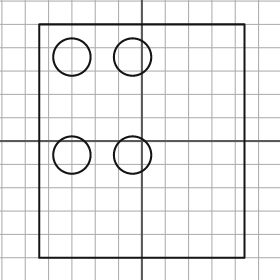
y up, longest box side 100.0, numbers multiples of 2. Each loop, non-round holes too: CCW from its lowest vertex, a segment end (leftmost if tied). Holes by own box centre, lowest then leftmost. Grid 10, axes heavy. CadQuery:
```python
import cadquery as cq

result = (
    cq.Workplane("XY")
    .moveTo(-44.0, -50.0)
    .lineTo(44.0, -50.0)
    .lineTo(44.0, 50.0)
    .lineTo(-44.0, 50.0)
    .close()
    .moveTo(-30.0, -6.0)
    .circle(8.0)
    .moveTo(-4.0, -6.0)
    .circle(8.0)
    .moveTo(-30.0, 36.0)
    .circle(8.0)
    .moveTo(-4.0, 36.0)
    .circle(8.0)
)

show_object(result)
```